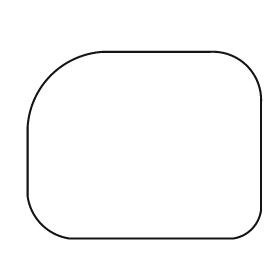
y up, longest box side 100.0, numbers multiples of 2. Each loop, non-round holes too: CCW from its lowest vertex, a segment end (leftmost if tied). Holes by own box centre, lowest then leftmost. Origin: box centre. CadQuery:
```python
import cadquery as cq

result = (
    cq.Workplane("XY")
    .moveTo(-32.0, -40.0)
    .lineTo(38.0, -40.0)
    .threePointArc((46.0, -36.0), (50.0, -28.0))
    .lineTo(50.0, 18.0)
    .threePointArc((44.0, 34.0), (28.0, 40.0))
    .lineTo(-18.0, 40.0)
    .threePointArc((-40.0, 30.0), (-50.0, 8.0))
    .lineTo(-50.0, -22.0)
    .threePointArc((-44.0, -34.0), (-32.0, -40.0))
    .close()
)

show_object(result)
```